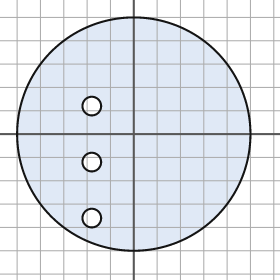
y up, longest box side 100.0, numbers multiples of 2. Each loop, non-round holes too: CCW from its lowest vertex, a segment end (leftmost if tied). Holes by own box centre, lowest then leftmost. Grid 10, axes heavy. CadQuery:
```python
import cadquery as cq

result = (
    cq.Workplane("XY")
    .moveTo(0.0, 0.0)
    .circle(50.0)
    .moveTo(-18.0, -36.0)
    .circle(4.0)
    .moveTo(-18.0, -12.0)
    .circle(4.0)
    .moveTo(-18.0, 12.0)
    .circle(4.0)
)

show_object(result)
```